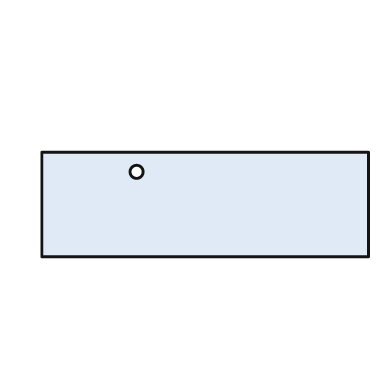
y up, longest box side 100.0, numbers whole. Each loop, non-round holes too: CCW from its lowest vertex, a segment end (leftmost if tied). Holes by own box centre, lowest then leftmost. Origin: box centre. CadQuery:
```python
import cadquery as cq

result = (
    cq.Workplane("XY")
    .moveTo(-50.0, -16.0)
    .lineTo(50.0, -16.0)
    .lineTo(50.0, 16.0)
    .lineTo(-50.0, 16.0)
    .close()
    .moveTo(-21.0, 10.0)
    .circle(2.0)
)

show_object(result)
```